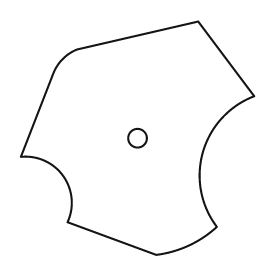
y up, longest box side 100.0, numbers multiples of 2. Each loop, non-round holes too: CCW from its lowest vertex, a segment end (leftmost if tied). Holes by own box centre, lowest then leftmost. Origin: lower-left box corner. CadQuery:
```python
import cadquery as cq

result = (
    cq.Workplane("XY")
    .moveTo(58.0, 0.0)
    .threePointArc((72.0, 4.0), (84.0, 12.0))
    .threePointArc((78.0, 44.0), (100.0, 68.0))
    .lineTo(76.0, 100.0)
    .lineTo(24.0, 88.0)
    .threePointArc((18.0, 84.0), (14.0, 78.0))
    .lineTo(0.0, 42.0)
    .threePointArc((18.0, 34.0), (20.0, 14.0))
    .close()
    .moveTo(50.0, 50.0)
    .circle(4.0)
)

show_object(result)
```